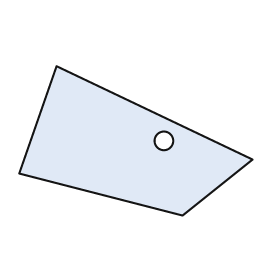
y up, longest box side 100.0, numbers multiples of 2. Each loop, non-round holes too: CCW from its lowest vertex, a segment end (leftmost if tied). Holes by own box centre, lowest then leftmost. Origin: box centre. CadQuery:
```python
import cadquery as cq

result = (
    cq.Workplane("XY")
    .moveTo(20.0, -32.0)
    .lineTo(50.0, -8.0)
    .lineTo(-34.0, 32.0)
    .lineTo(-50.0, -14.0)
    .close()
    .moveTo(12.0, 0.0)
    .circle(4.0)
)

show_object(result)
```